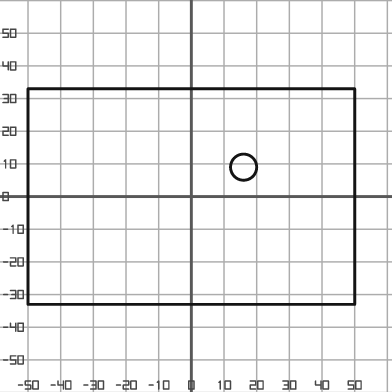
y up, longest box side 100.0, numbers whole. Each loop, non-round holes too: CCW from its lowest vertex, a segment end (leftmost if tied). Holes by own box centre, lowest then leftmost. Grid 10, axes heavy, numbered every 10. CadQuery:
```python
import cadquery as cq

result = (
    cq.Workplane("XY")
    .moveTo(-50.0, -33.0)
    .lineTo(50.0, -33.0)
    .lineTo(50.0, 33.0)
    .lineTo(-50.0, 33.0)
    .close()
    .moveTo(16.0, 9.0)
    .circle(4.0)
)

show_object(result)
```